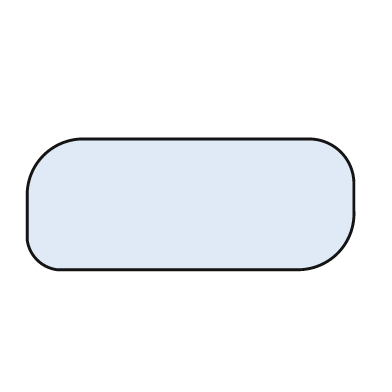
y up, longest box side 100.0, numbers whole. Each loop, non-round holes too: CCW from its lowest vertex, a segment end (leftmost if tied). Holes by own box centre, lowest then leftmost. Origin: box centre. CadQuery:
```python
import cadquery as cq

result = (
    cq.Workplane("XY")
    .moveTo(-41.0, -20.0)
    .lineTo(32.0, -20.0)
    .threePointArc((45.0, -15.0), (50.0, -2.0))
    .lineTo(50.0, 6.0)
    .threePointArc((46.0, 16.0), (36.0, 20.0))
    .lineTo(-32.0, 20.0)
    .threePointArc((-45.0, 15.0), (-50.0, 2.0))
    .lineTo(-50.0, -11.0)
    .threePointArc((-47.0, -17.0), (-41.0, -20.0))
    .close()
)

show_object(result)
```